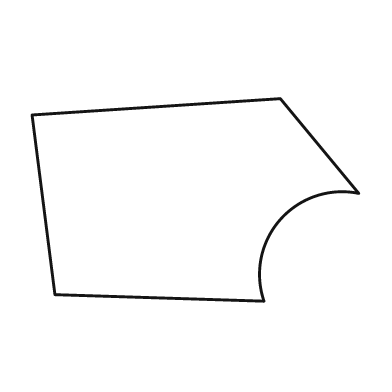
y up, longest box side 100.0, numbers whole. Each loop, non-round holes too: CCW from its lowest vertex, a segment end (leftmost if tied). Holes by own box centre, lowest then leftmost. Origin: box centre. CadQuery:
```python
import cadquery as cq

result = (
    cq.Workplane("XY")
    .moveTo(21.0, -31.0)
    .threePointArc((26.0, -6.0), (50.0, 2.0))
    .lineTo(26.0, 31.0)
    .lineTo(-50.0, 26.0)
    .lineTo(-43.0, -29.0)
    .close()
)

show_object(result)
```